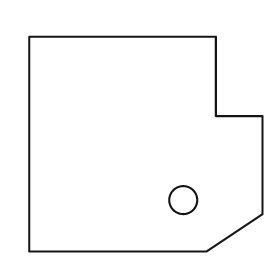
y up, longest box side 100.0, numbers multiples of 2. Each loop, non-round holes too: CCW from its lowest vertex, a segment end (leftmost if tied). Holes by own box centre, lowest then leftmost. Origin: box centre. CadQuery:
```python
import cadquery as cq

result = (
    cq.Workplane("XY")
    .moveTo(-50.0, -46.0)
    .lineTo(26.0, -46.0)
    .lineTo(50.0, -30.0)
    .lineTo(50.0, 12.0)
    .lineTo(30.0, 12.0)
    .lineTo(30.0, 46.0)
    .lineTo(-50.0, 46.0)
    .close()
    .moveTo(16.0, -24.0)
    .circle(6.0)
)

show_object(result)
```